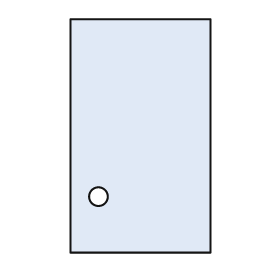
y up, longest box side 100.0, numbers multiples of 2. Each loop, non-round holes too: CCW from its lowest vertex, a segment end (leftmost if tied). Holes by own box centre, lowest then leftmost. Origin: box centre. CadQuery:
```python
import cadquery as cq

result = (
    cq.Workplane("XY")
    .moveTo(-30.0, -50.0)
    .lineTo(30.0, -50.0)
    .lineTo(30.0, 50.0)
    .lineTo(-30.0, 50.0)
    .close()
    .moveTo(-18.0, -26.0)
    .circle(4.0)
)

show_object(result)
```